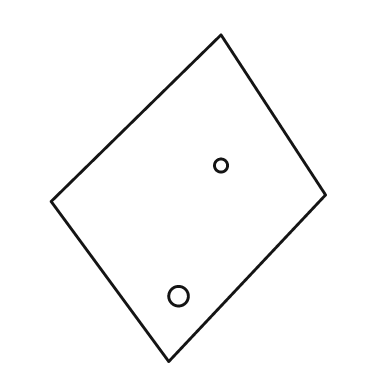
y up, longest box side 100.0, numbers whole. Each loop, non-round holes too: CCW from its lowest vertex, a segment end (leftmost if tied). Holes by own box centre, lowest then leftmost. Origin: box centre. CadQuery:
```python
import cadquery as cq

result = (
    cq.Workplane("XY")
    .moveTo(-6.0, -50.0)
    .lineTo(42.0, 1.0)
    .lineTo(10.0, 50.0)
    .lineTo(-42.0, -1.0)
    .close()
    .moveTo(-3.0, -30.0)
    .circle(3.0)
    .moveTo(10.0, 10.0)
    .circle(2.0)
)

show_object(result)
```